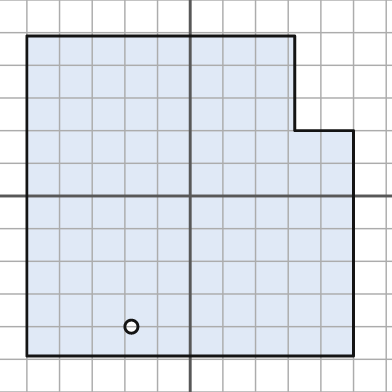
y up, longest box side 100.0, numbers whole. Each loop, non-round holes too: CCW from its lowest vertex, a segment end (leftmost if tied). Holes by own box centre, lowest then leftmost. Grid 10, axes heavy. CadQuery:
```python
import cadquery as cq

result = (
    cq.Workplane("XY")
    .moveTo(-50.0, -49.0)
    .lineTo(50.0, -49.0)
    .lineTo(50.0, 20.0)
    .lineTo(32.0, 20.0)
    .lineTo(32.0, 49.0)
    .lineTo(-50.0, 49.0)
    .close()
    .moveTo(-18.0, -40.0)
    .circle(2.0)
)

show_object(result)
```